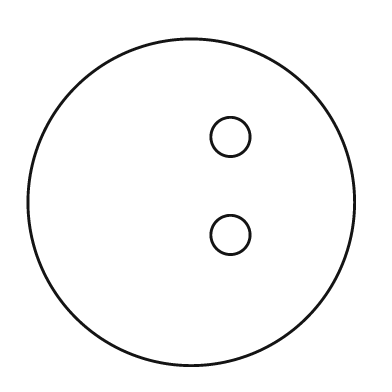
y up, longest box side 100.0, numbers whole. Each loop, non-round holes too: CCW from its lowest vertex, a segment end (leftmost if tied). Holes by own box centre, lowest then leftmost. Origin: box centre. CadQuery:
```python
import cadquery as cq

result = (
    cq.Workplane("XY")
    .moveTo(0.0, 0.0)
    .circle(50.0)
    .moveTo(12.0, -10.0)
    .circle(6.0)
    .moveTo(12.0, 20.0)
    .circle(6.0)
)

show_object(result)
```